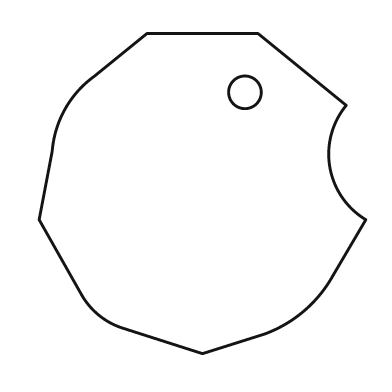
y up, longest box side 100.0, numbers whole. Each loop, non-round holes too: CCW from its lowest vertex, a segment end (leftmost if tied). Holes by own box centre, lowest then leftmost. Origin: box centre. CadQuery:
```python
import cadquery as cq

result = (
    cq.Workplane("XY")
    .moveTo(0.0, -49.0)
    .lineTo(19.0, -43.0)
    .threePointArc((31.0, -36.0), (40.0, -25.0))
    .lineTo(50.0, -8.0)
    .threePointArc((39.0, 8.0), (44.0, 27.0))
    .lineTo(17.0, 49.0)
    .lineTo(-17.0, 49.0)
    .lineTo(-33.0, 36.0)
    .threePointArc((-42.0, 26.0), (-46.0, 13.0))
    .lineTo(-50.0, -8.0)
    .lineTo(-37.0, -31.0)
    .threePointArc((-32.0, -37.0), (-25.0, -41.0))
    .close()
    .moveTo(13.0, 31.0)
    .circle(5.0)
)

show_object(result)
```